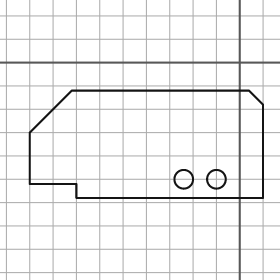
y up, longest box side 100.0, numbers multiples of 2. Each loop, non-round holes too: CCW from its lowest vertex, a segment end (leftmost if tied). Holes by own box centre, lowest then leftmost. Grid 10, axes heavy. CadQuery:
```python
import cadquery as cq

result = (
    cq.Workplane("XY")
    .moveTo(-70.0, -58.0)
    .lineTo(10.0, -58.0)
    .lineTo(10.0, -18.0)
    .lineTo(4.0, -12.0)
    .lineTo(-72.0, -12.0)
    .lineTo(-90.0, -30.0)
    .lineTo(-90.0, -52.0)
    .lineTo(-70.0, -52.0)
    .close()
    .moveTo(-24.0, -50.0)
    .circle(4.0)
    .moveTo(-10.0, -50.0)
    .circle(4.0)
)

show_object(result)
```